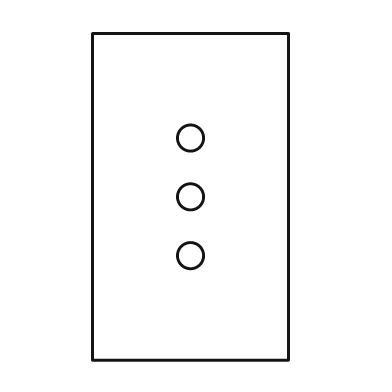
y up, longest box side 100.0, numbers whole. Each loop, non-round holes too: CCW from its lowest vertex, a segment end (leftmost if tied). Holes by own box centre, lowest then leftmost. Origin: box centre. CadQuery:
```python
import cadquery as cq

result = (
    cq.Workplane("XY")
    .moveTo(-30.0, -50.0)
    .lineTo(30.0, -50.0)
    .lineTo(30.0, 50.0)
    .lineTo(-30.0, 50.0)
    .close()
    .moveTo(0.0, -18.0)
    .circle(4.0)
    .moveTo(0.0, 0.0)
    .circle(4.0)
    .moveTo(0.0, 18.0)
    .circle(4.0)
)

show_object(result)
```